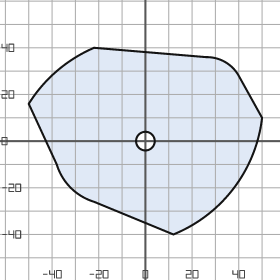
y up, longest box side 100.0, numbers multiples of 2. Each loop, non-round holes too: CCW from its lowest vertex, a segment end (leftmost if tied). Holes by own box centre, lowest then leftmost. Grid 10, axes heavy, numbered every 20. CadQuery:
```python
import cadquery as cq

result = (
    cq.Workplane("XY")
    .moveTo(12.0, -40.0)
    .threePointArc((38.0, -20.0), (50.0, 10.0))
    .lineTo(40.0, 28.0)
    .threePointArc((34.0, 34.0), (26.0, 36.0))
    .lineTo(-22.0, 40.0)
    .threePointArc((-38.0, 30.0), (-50.0, 16.0))
    .lineTo(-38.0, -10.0)
    .threePointArc((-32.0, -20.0), (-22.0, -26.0))
    .close()
    .moveTo(0.0, 0.0)
    .circle(4.0)
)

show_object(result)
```